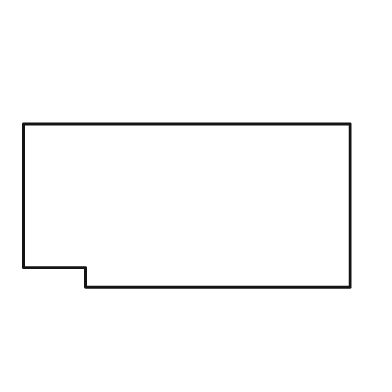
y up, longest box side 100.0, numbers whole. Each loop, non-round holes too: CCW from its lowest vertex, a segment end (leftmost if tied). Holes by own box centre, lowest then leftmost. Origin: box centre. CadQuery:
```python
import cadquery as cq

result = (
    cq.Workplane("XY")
    .moveTo(-31.0, -25.0)
    .lineTo(50.0, -25.0)
    .lineTo(50.0, 25.0)
    .lineTo(-50.0, 25.0)
    .lineTo(-50.0, -19.0)
    .lineTo(-31.0, -19.0)
    .close()
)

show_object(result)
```